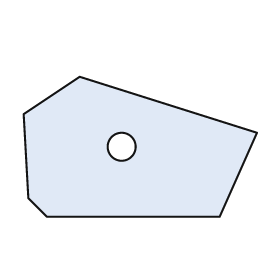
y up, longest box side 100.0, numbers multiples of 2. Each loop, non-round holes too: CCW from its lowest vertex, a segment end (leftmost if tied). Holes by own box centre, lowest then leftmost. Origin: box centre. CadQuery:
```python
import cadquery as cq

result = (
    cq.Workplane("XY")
    .moveTo(-40.0, -30.0)
    .lineTo(34.0, -30.0)
    .lineTo(50.0, 6.0)
    .lineTo(-26.0, 30.0)
    .lineTo(-50.0, 14.0)
    .lineTo(-48.0, -22.0)
    .close()
    .moveTo(-8.0, 0.0)
    .circle(6.0)
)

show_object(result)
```